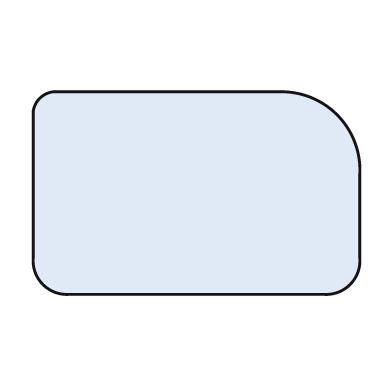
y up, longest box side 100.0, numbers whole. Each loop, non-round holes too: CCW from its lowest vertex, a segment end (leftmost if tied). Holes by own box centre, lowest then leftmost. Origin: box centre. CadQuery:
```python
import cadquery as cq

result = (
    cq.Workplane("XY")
    .moveTo(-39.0, -31.0)
    .lineTo(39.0, -31.0)
    .threePointArc((47.0, -28.0), (50.0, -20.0))
    .lineTo(50.0, 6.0)
    .threePointArc((43.0, 24.0), (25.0, 31.0))
    .lineTo(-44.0, 31.0)
    .threePointArc((-48.0, 29.0), (-50.0, 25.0))
    .lineTo(-50.0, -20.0)
    .threePointArc((-47.0, -28.0), (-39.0, -31.0))
    .close()
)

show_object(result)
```